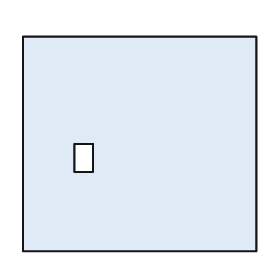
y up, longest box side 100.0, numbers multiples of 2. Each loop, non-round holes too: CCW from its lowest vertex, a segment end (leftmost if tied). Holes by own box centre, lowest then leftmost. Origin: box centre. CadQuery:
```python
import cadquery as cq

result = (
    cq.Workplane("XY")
    .moveTo(-50.0, -46.0)
    .lineTo(50.0, -46.0)
    .lineTo(50.0, 46.0)
    .lineTo(-50.0, 46.0)
    .close()
    .moveTo(-28.0, -12.0)
    .lineTo(-20.0, -12.0)
    .lineTo(-20.0, 0.0)
    .lineTo(-28.0, 0.0)
    .close()
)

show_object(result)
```